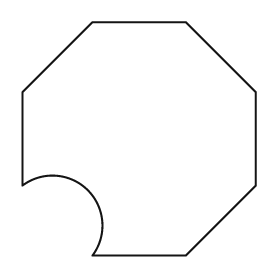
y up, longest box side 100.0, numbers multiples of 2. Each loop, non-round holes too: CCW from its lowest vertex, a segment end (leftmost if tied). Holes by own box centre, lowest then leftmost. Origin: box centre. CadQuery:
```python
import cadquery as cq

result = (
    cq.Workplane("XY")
    .moveTo(-20.0, -50.0)
    .lineTo(20.0, -50.0)
    .lineTo(50.0, -20.0)
    .lineTo(50.0, 20.0)
    .lineTo(20.0, 50.0)
    .lineTo(-20.0, 50.0)
    .lineTo(-50.0, 20.0)
    .lineTo(-50.0, -20.0)
    .threePointArc((-22.0, -22.0), (-20.0, -50.0))
    .close()
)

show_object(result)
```